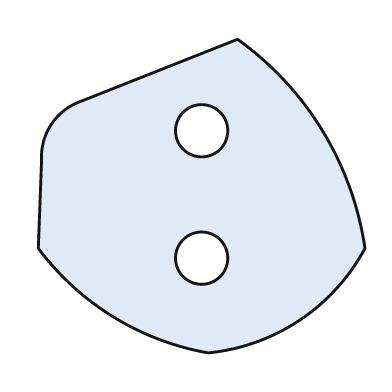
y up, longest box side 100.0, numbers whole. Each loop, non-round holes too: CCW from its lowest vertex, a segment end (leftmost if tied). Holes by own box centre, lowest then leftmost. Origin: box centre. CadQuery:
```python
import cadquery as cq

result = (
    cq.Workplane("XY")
    .moveTo(2.0, -48.0)
    .threePointArc((30.0, -38.0), (50.0, -16.0))
    .threePointArc((37.0, 20.0), (11.0, 48.0))
    .lineTo(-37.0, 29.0)
    .threePointArc((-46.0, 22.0), (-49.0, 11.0))
    .lineTo(-50.0, -16.0)
    .threePointArc((-27.0, -37.0), (2.0, -48.0))
    .close()
    .moveTo(0.0, -19.0)
    .circle(8.0)
    .moveTo(0.0, 20.0)
    .circle(8.0)
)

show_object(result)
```